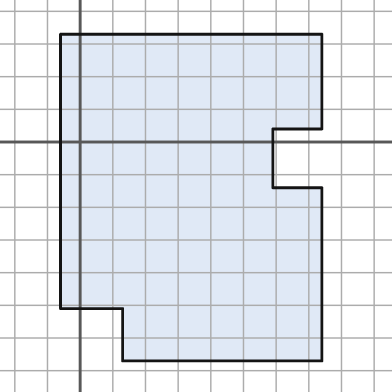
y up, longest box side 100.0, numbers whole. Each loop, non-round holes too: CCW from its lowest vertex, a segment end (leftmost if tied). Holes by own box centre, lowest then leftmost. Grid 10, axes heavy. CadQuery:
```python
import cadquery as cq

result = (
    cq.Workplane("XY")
    .moveTo(13.0, -67.0)
    .lineTo(74.0, -67.0)
    .lineTo(74.0, -14.0)
    .lineTo(59.0, -14.0)
    .lineTo(59.0, 4.0)
    .lineTo(74.0, 4.0)
    .lineTo(74.0, 33.0)
    .lineTo(-6.0, 33.0)
    .lineTo(-6.0, -51.0)
    .lineTo(13.0, -51.0)
    .close()
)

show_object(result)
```